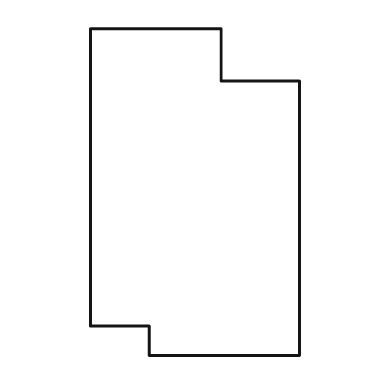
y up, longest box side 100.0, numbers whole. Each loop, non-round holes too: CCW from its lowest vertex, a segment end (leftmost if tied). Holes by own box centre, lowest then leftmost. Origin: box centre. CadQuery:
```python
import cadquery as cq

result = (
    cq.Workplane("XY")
    .moveTo(-14.0, -50.0)
    .lineTo(32.0, -50.0)
    .lineTo(32.0, 34.0)
    .lineTo(8.0, 34.0)
    .lineTo(8.0, 50.0)
    .lineTo(-32.0, 50.0)
    .lineTo(-32.0, -41.0)
    .lineTo(-14.0, -41.0)
    .close()
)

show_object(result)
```